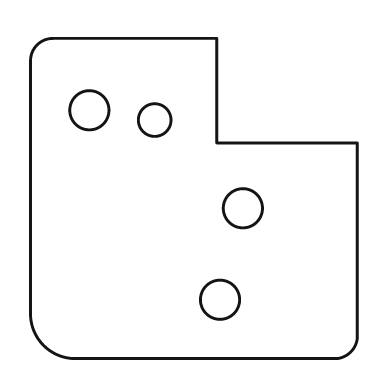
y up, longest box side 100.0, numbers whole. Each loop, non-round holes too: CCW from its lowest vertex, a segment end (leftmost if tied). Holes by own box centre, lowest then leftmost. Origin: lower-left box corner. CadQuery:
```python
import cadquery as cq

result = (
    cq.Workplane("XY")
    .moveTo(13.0, 0.0)
    .lineTo(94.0, 0.0)
    .threePointArc((98.0, 2.0), (100.0, 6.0))
    .lineTo(100.0, 66.0)
    .lineTo(57.0, 66.0)
    .lineTo(57.0, 98.0)
    .lineTo(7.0, 98.0)
    .threePointArc((2.0, 96.0), (0.0, 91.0))
    .lineTo(0.0, 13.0)
    .threePointArc((4.0, 4.0), (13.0, 0.0))
    .close()
    .moveTo(58.0, 18.0)
    .circle(6.0)
    .moveTo(65.0, 46.0)
    .circle(6.0)
    .moveTo(38.0, 73.0)
    .circle(5.0)
    .moveTo(18.0, 76.0)
    .circle(6.0)
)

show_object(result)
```